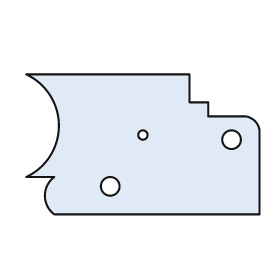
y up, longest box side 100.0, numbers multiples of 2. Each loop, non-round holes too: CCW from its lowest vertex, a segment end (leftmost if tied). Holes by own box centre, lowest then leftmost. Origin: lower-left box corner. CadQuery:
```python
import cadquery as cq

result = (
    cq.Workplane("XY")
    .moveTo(12.0, 0.0)
    .lineTo(100.0, 0.0)
    .lineTo(100.0, 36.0)
    .threePointArc((98.0, 40.0), (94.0, 42.0))
    .lineTo(78.0, 42.0)
    .lineTo(78.0, 48.0)
    .lineTo(70.0, 48.0)
    .lineTo(70.0, 60.0)
    .lineTo(0.0, 60.0)
    .threePointArc((14.0, 38.0), (0.0, 16.0))
    .lineTo(12.0, 16.0)
    .threePointArc((8.0, 8.0), (12.0, 0.0))
    .close()
    .moveTo(36.0, 12.0)
    .circle(4.0)
    .moveTo(88.0, 32.0)
    .circle(4.0)
    .moveTo(50.0, 34.0)
    .circle(2.0)
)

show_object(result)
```